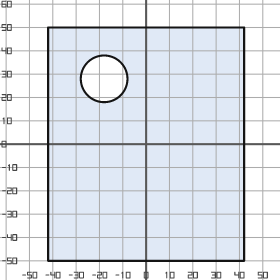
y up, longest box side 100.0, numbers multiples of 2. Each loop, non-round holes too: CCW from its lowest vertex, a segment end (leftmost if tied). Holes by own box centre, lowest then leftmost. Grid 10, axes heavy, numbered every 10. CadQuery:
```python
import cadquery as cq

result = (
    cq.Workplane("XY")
    .moveTo(-42.0, -50.0)
    .lineTo(42.0, -50.0)
    .lineTo(42.0, 50.0)
    .lineTo(-42.0, 50.0)
    .close()
    .moveTo(-18.0, 28.0)
    .circle(10.0)
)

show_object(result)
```